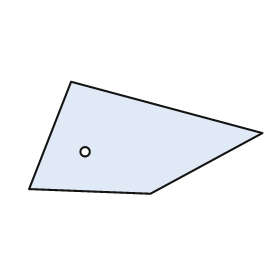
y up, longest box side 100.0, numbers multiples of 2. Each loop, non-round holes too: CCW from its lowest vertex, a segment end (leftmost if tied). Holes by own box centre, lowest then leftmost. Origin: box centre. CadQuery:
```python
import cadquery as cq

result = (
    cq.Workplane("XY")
    .moveTo(2.0, -24.0)
    .lineTo(50.0, 2.0)
    .lineTo(-32.0, 24.0)
    .lineTo(-50.0, -22.0)
    .close()
    .moveTo(-26.0, -6.0)
    .circle(2.0)
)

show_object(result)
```